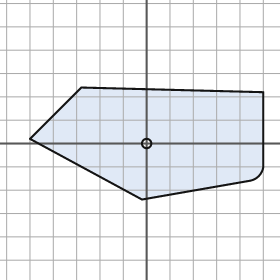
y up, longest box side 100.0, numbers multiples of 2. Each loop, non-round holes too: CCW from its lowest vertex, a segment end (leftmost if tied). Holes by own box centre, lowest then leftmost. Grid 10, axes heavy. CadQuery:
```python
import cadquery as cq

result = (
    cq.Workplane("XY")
    .moveTo(-2.0, -24.0)
    .lineTo(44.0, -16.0)
    .threePointArc((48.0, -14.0), (50.0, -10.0))
    .lineTo(50.0, 22.0)
    .lineTo(-28.0, 24.0)
    .lineTo(-50.0, 2.0)
    .close()
    .moveTo(0.0, 0.0)
    .circle(2.0)
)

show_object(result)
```